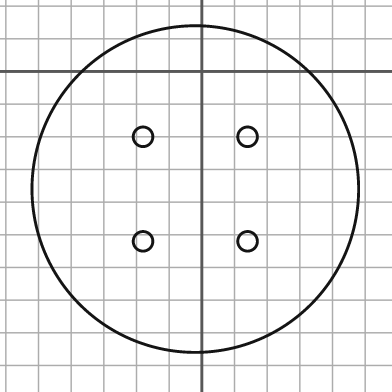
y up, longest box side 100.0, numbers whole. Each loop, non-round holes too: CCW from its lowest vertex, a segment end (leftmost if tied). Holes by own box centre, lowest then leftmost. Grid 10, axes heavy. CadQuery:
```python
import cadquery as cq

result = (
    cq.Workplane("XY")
    .moveTo(-2.0, -36.0)
    .circle(50.0)
    .moveTo(-18.0, -52.0)
    .circle(3.0)
    .moveTo(14.0, -52.0)
    .circle(3.0)
    .moveTo(-18.0, -20.0)
    .circle(3.0)
    .moveTo(14.0, -20.0)
    .circle(3.0)
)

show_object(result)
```